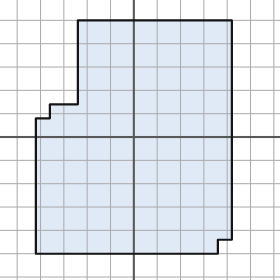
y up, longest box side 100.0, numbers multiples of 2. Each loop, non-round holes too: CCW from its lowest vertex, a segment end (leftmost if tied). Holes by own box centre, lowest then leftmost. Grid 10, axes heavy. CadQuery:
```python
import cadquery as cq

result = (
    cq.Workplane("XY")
    .moveTo(-42.0, -50.0)
    .lineTo(36.0, -50.0)
    .lineTo(36.0, -44.0)
    .lineTo(42.0, -44.0)
    .lineTo(42.0, 50.0)
    .lineTo(-24.0, 50.0)
    .lineTo(-24.0, 14.0)
    .lineTo(-36.0, 14.0)
    .lineTo(-36.0, 8.0)
    .lineTo(-42.0, 8.0)
    .close()
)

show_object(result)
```